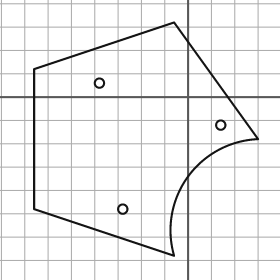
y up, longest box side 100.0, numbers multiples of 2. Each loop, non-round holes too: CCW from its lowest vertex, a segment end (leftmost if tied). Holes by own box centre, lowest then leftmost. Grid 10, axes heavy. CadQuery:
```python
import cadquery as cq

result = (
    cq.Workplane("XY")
    .moveTo(-6.0, -68.0)
    .threePointArc((0.0, -34.0), (30.0, -18.0))
    .lineTo(-6.0, 32.0)
    .lineTo(-66.0, 12.0)
    .lineTo(-66.0, -48.0)
    .close()
    .moveTo(-28.0, -48.0)
    .circle(2.0)
    .moveTo(14.0, -12.0)
    .circle(2.0)
    .moveTo(-38.0, 6.0)
    .circle(2.0)
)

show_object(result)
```